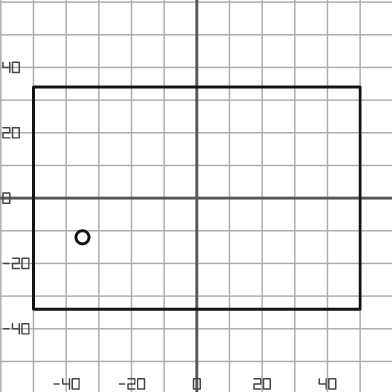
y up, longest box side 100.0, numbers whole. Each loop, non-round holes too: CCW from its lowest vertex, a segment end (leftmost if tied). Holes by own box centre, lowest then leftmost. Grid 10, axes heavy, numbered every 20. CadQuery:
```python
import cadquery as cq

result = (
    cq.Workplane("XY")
    .moveTo(-50.0, -34.0)
    .lineTo(50.0, -34.0)
    .lineTo(50.0, 34.0)
    .lineTo(-50.0, 34.0)
    .close()
    .moveTo(-35.0, -12.0)
    .circle(2.0)
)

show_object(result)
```